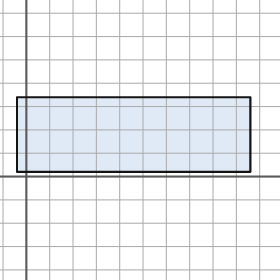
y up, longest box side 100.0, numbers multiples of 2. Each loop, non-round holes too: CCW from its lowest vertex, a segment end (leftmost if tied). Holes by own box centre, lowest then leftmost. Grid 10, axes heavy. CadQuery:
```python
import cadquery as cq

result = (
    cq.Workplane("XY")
    .moveTo(-4.0, 2.0)
    .lineTo(96.0, 2.0)
    .lineTo(96.0, 34.0)
    .lineTo(-4.0, 34.0)
    .close()
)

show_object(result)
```